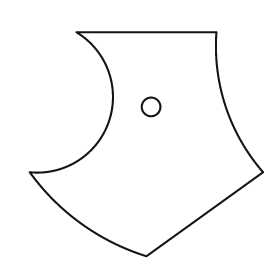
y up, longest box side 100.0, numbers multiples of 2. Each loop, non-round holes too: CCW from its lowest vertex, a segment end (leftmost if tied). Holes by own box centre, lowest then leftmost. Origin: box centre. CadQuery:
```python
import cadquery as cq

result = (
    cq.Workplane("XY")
    .moveTo(0.0, -48.0)
    .lineTo(50.0, -12.0)
    .threePointArc((34.0, 16.0), (30.0, 48.0))
    .lineTo(-30.0, 48.0)
    .threePointArc((-16.0, 10.0), (-50.0, -12.0))
    .threePointArc((-28.0, -34.0), (0.0, -48.0))
    .close()
    .moveTo(2.0, 16.0)
    .circle(4.0)
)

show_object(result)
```